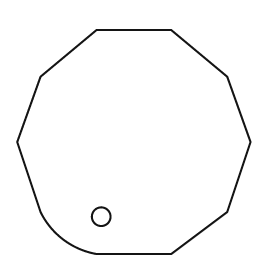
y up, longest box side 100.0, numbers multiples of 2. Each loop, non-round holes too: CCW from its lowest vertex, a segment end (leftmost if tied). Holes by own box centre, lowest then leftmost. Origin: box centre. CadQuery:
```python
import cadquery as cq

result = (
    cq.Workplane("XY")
    .moveTo(-16.0, -48.0)
    .lineTo(16.0, -48.0)
    .lineTo(40.0, -30.0)
    .lineTo(50.0, 0.0)
    .lineTo(40.0, 28.0)
    .lineTo(16.0, 48.0)
    .lineTo(-16.0, 48.0)
    .lineTo(-40.0, 28.0)
    .lineTo(-50.0, 0.0)
    .lineTo(-40.0, -30.0)
    .threePointArc((-30.0, -42.0), (-16.0, -48.0))
    .close()
    .moveTo(-14.0, -32.0)
    .circle(4.0)
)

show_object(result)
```